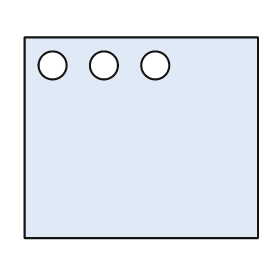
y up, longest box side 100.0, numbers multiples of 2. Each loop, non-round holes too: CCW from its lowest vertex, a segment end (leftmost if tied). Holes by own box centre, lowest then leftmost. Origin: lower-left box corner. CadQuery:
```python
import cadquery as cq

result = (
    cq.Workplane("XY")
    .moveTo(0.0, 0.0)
    .lineTo(100.0, 0.0)
    .lineTo(100.0, 86.0)
    .lineTo(0.0, 86.0)
    .close()
    .moveTo(12.0, 74.0)
    .circle(6.0)
    .moveTo(34.0, 74.0)
    .circle(6.0)
    .moveTo(56.0, 74.0)
    .circle(6.0)
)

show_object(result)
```